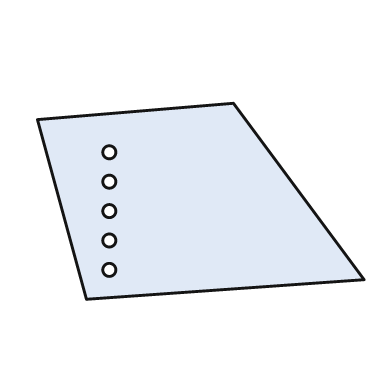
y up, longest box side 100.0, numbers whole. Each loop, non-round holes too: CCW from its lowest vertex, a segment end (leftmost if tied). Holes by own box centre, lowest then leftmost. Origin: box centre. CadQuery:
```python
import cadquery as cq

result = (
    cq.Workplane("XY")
    .moveTo(-35.0, -30.0)
    .lineTo(50.0, -24.0)
    .lineTo(10.0, 30.0)
    .lineTo(-50.0, 25.0)
    .close()
    .moveTo(-28.0, -21.0)
    .circle(2.0)
    .moveTo(-28.0, -12.0)
    .circle(2.0)
    .moveTo(-28.0, -3.0)
    .circle(2.0)
    .moveTo(-28.0, 6.0)
    .circle(2.0)
    .moveTo(-28.0, 15.0)
    .circle(2.0)
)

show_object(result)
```